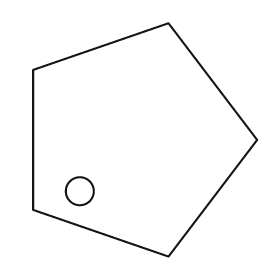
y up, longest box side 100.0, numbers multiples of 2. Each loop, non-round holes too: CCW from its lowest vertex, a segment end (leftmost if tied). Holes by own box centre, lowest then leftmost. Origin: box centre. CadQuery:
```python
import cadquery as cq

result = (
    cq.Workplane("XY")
    .moveTo(10.0, -50.0)
    .lineTo(48.0, 0.0)
    .lineTo(10.0, 50.0)
    .lineTo(-48.0, 30.0)
    .lineTo(-48.0, -30.0)
    .close()
    .moveTo(-28.0, -22.0)
    .circle(6.0)
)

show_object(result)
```